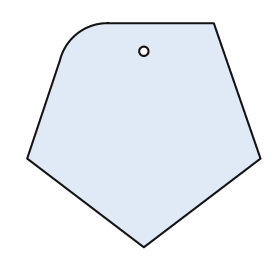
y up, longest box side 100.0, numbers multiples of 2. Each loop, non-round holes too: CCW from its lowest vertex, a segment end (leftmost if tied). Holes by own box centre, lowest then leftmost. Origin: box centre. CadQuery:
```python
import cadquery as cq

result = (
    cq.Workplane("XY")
    .moveTo(0.0, -48.0)
    .lineTo(50.0, -10.0)
    .lineTo(30.0, 48.0)
    .lineTo(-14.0, 48.0)
    .threePointArc((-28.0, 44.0), (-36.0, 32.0))
    .lineTo(-50.0, -10.0)
    .close()
    .moveTo(0.0, 36.0)
    .circle(2.0)
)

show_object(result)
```